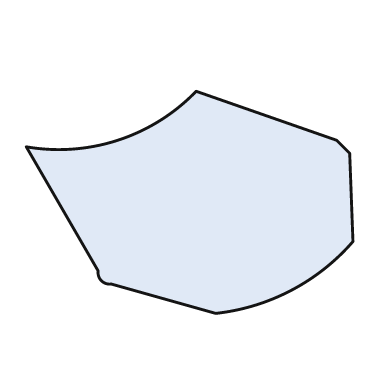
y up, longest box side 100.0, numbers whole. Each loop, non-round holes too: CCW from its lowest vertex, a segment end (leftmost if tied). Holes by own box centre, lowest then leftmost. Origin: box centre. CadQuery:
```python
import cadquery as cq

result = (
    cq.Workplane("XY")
    .moveTo(8.0, -34.0)
    .threePointArc((31.0, -27.0), (50.0, -12.0))
    .lineTo(49.0, 15.0)
    .lineTo(45.0, 19.0)
    .lineTo(2.0, 34.0)
    .threePointArc((-22.0, 19.0), (-50.0, 17.0))
    .lineTo(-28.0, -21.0)
    .threePointArc((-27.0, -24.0), (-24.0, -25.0))
    .close()
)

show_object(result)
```